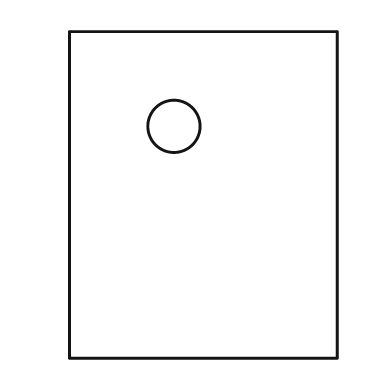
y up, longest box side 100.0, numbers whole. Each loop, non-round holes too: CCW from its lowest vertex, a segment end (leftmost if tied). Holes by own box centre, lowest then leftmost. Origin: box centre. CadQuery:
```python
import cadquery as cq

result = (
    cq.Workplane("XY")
    .moveTo(-41.0, -50.0)
    .lineTo(41.0, -50.0)
    .lineTo(41.0, 50.0)
    .lineTo(-41.0, 50.0)
    .close()
    .moveTo(-9.0, 21.0)
    .circle(8.0)
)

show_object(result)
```